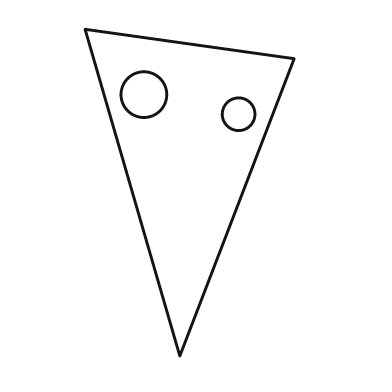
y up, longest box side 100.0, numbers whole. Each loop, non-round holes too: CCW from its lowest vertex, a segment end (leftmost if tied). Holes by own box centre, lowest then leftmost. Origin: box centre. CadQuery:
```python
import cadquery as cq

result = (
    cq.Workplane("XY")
    .moveTo(-3.0, -50.0)
    .lineTo(32.0, 41.0)
    .lineTo(-32.0, 50.0)
    .close()
    .moveTo(15.0, 24.0)
    .circle(5.0)
    .moveTo(-14.0, 30.0)
    .circle(7.0)
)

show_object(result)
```